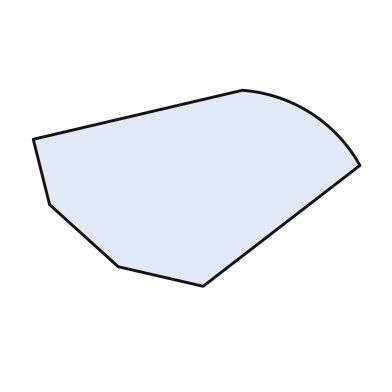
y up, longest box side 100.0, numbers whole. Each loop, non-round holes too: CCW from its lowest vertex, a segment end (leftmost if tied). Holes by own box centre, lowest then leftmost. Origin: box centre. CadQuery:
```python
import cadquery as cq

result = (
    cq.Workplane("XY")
    .moveTo(2.0, -30.0)
    .lineTo(50.0, 7.0)
    .threePointArc((35.0, 23.0), (14.0, 30.0))
    .lineTo(-50.0, 15.0)
    .lineTo(-45.0, -5.0)
    .lineTo(-24.0, -24.0)
    .close()
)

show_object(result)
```